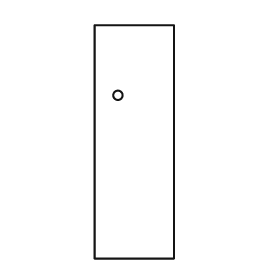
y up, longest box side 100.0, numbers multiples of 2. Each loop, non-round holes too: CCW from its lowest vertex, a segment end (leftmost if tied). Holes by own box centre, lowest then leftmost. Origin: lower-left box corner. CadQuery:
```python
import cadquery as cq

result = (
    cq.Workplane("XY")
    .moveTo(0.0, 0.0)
    .lineTo(34.0, 0.0)
    .lineTo(34.0, 100.0)
    .lineTo(0.0, 100.0)
    .close()
    .moveTo(10.0, 70.0)
    .circle(2.0)
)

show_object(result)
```